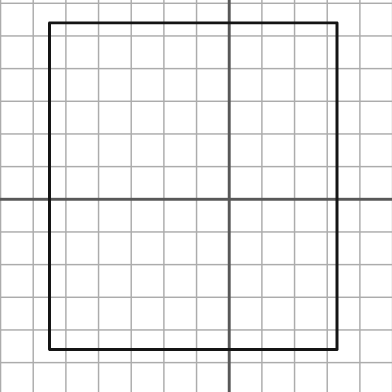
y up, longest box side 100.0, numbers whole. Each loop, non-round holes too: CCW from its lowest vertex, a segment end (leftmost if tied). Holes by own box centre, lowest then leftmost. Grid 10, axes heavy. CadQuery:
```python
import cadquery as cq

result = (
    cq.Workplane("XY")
    .moveTo(-55.0, -46.0)
    .lineTo(33.0, -46.0)
    .lineTo(33.0, 54.0)
    .lineTo(-55.0, 54.0)
    .close()
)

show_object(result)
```